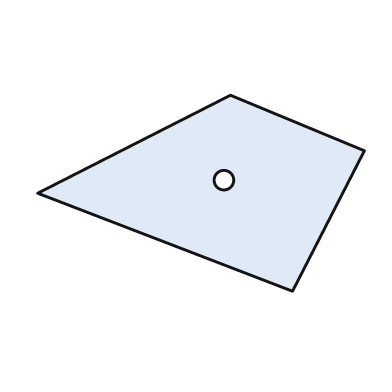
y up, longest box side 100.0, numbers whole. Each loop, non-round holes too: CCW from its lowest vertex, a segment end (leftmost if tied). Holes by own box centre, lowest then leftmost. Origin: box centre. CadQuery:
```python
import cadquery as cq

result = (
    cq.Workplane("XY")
    .moveTo(28.0, -30.0)
    .lineTo(50.0, 13.0)
    .lineTo(9.0, 30.0)
    .lineTo(-50.0, 0.0)
    .close()
    .moveTo(7.0, 4.0)
    .circle(3.0)
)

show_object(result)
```